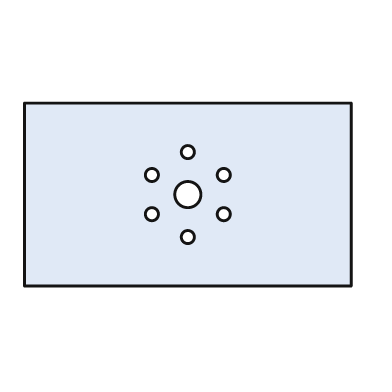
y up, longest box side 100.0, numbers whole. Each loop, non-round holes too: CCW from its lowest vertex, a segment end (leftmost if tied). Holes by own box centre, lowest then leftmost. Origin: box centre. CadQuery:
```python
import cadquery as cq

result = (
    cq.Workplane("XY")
    .moveTo(-50.0, -28.0)
    .lineTo(50.0, -28.0)
    .lineTo(50.0, 28.0)
    .lineTo(-50.0, 28.0)
    .close()
    .moveTo(0.0, -13.0)
    .circle(2.0)
    .moveTo(-11.0, -6.0)
    .circle(2.0)
    .moveTo(11.0, -6.0)
    .circle(2.0)
    .moveTo(0.0, 0.0)
    .circle(4.0)
    .moveTo(-11.0, 6.0)
    .circle(2.0)
    .moveTo(11.0, 6.0)
    .circle(2.0)
    .moveTo(0.0, 13.0)
    .circle(2.0)
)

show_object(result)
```